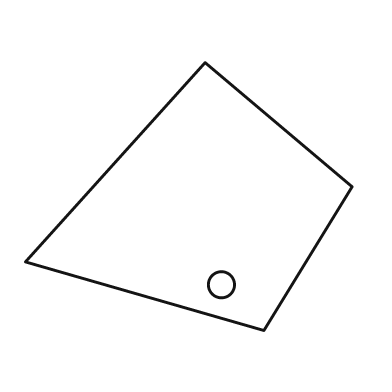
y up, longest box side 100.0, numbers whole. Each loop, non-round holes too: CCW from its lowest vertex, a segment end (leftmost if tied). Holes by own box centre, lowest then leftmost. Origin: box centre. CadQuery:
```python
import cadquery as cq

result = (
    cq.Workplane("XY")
    .moveTo(23.0, -41.0)
    .lineTo(50.0, 3.0)
    .lineTo(5.0, 41.0)
    .lineTo(-50.0, -20.0)
    .close()
    .moveTo(10.0, -27.0)
    .circle(4.0)
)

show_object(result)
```